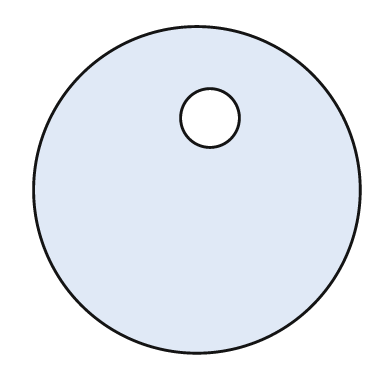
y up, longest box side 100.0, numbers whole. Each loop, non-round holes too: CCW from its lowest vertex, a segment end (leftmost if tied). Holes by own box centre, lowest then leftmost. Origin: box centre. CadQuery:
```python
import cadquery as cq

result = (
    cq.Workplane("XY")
    .moveTo(0.0, 0.0)
    .circle(50.0)
    .moveTo(4.0, 22.0)
    .circle(9.0)
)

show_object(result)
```